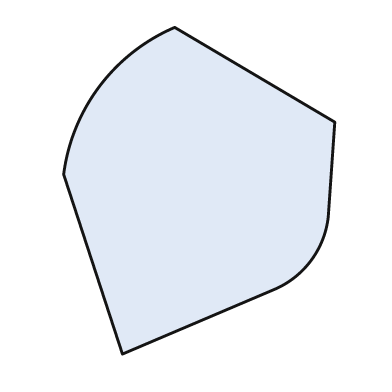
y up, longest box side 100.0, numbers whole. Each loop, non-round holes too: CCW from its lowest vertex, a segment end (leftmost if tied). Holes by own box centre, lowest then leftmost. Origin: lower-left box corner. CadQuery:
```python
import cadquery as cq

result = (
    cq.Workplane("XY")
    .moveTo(18.0, 0.0)
    .lineTo(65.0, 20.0)
    .threePointArc((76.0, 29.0), (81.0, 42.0))
    .lineTo(83.0, 71.0)
    .lineTo(34.0, 100.0)
    .threePointArc((11.0, 82.0), (0.0, 55.0))
    .close()
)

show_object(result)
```